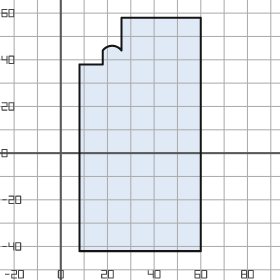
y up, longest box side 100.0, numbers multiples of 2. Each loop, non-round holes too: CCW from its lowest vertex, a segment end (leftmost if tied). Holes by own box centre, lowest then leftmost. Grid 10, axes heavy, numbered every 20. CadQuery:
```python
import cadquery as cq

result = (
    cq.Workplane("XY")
    .moveTo(8.0, -42.0)
    .lineTo(60.0, -42.0)
    .lineTo(60.0, 58.0)
    .lineTo(26.0, 58.0)
    .lineTo(26.0, 44.0)
    .threePointArc((22.0, 46.0), (18.0, 44.0))
    .lineTo(18.0, 38.0)
    .lineTo(8.0, 38.0)
    .close()
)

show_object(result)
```